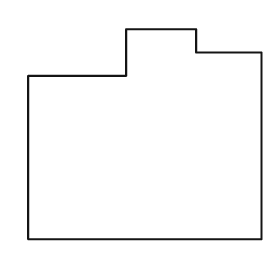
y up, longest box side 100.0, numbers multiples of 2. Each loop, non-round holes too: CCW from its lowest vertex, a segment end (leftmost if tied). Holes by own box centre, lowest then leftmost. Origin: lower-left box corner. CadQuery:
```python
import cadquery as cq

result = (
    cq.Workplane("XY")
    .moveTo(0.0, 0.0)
    .lineTo(100.0, 0.0)
    .lineTo(100.0, 80.0)
    .lineTo(72.0, 80.0)
    .lineTo(72.0, 90.0)
    .lineTo(42.0, 90.0)
    .lineTo(42.0, 70.0)
    .lineTo(0.0, 70.0)
    .close()
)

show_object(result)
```